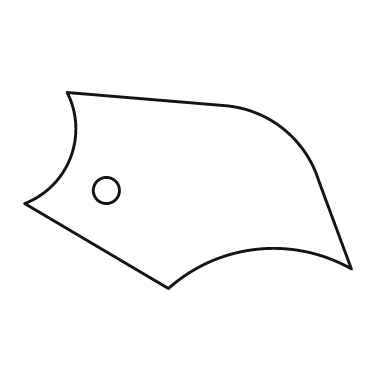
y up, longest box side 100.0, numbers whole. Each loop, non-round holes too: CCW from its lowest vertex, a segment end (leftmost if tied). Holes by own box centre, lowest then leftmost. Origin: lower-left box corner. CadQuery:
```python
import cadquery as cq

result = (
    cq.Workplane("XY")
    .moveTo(44.0, 0.0)
    .threePointArc((71.0, 12.0), (100.0, 6.0))
    .lineTo(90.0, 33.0)
    .threePointArc((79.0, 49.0), (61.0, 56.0))
    .lineTo(13.0, 60.0)
    .threePointArc((14.0, 40.0), (0.0, 26.0))
    .close()
    .moveTo(25.0, 30.0)
    .circle(4.0)
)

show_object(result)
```